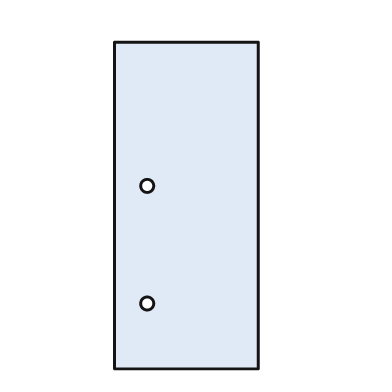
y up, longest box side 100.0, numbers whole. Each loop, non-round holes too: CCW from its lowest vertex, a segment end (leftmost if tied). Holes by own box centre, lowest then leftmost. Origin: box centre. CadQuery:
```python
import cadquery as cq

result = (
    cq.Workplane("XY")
    .moveTo(-22.0, -50.0)
    .lineTo(22.0, -50.0)
    .lineTo(22.0, 50.0)
    .lineTo(-22.0, 50.0)
    .close()
    .moveTo(-12.0, -30.0)
    .circle(2.0)
    .moveTo(-12.0, 6.0)
    .circle(2.0)
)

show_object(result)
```